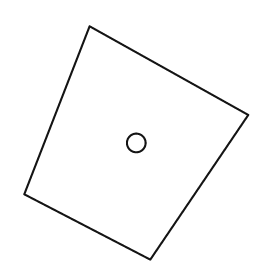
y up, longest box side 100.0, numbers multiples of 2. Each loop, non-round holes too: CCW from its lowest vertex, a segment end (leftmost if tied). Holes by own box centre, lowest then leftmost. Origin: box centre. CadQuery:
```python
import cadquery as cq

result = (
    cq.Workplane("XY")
    .moveTo(6.0, -50.0)
    .lineTo(48.0, 12.0)
    .lineTo(-20.0, 50.0)
    .lineTo(-48.0, -22.0)
    .close()
    .moveTo(0.0, 0.0)
    .circle(4.0)
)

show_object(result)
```